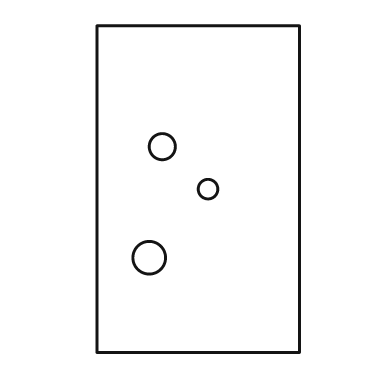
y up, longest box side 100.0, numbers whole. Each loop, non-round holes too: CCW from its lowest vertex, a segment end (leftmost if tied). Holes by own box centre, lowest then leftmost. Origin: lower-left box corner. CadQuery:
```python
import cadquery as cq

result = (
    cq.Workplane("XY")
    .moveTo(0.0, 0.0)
    .lineTo(62.0, 0.0)
    .lineTo(62.0, 100.0)
    .lineTo(0.0, 100.0)
    .close()
    .moveTo(16.0, 29.0)
    .circle(5.0)
    .moveTo(34.0, 50.0)
    .circle(3.0)
    .moveTo(20.0, 63.0)
    .circle(4.0)
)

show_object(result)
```